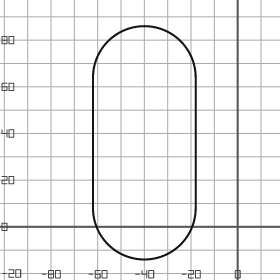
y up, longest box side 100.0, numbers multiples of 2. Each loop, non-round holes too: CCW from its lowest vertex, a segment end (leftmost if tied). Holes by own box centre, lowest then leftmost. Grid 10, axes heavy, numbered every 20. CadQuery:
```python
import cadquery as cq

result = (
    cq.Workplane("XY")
    .moveTo(-62.0, 8.0)
    .threePointArc((-40.0, -14.0), (-18.0, 8.0))
    .lineTo(-18.0, 64.0)
    .threePointArc((-40.0, 86.0), (-62.0, 64.0))
    .close()
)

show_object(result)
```